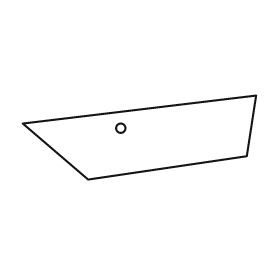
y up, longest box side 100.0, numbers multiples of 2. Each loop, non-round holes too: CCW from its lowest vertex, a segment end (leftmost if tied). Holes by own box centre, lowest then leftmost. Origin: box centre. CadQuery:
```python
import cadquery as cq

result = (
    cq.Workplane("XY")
    .moveTo(-22.0, -18.0)
    .lineTo(46.0, -8.0)
    .lineTo(50.0, 18.0)
    .lineTo(-50.0, 6.0)
    .close()
    .moveTo(-8.0, 4.0)
    .circle(2.0)
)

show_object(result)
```